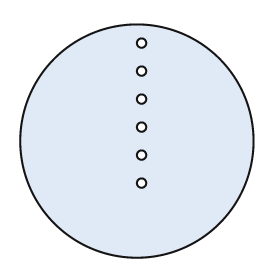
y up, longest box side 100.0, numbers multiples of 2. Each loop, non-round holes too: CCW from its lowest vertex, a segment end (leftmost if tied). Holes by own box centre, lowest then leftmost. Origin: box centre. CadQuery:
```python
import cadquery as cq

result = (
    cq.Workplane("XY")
    .moveTo(0.0, 0.0)
    .circle(50.0)
    .moveTo(2.0, -18.0)
    .circle(2.0)
    .moveTo(2.0, -6.0)
    .circle(2.0)
    .moveTo(2.0, 6.0)
    .circle(2.0)
    .moveTo(2.0, 18.0)
    .circle(2.0)
    .moveTo(2.0, 30.0)
    .circle(2.0)
    .moveTo(2.0, 42.0)
    .circle(2.0)
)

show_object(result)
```